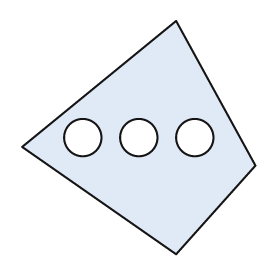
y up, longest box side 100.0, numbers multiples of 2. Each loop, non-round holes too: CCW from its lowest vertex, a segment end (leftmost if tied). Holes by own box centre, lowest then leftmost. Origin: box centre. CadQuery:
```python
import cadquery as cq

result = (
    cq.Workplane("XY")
    .moveTo(16.0, -50.0)
    .lineTo(50.0, -12.0)
    .lineTo(16.0, 50.0)
    .lineTo(-50.0, -4.0)
    .close()
    .moveTo(-24.0, 0.0)
    .circle(8.0)
    .moveTo(0.0, 0.0)
    .circle(8.0)
    .moveTo(24.0, 0.0)
    .circle(8.0)
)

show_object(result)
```